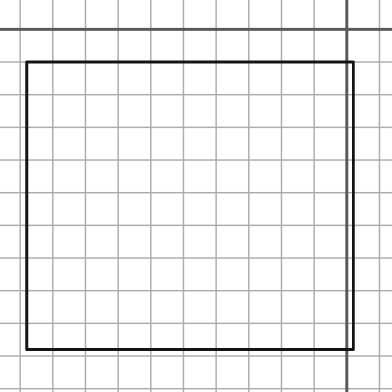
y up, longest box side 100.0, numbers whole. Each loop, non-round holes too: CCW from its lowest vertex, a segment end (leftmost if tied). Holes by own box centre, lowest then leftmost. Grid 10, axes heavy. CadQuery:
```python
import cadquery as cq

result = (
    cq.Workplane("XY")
    .moveTo(-98.0, -98.0)
    .lineTo(2.0, -98.0)
    .lineTo(2.0, -10.0)
    .lineTo(-98.0, -10.0)
    .close()
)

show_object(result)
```